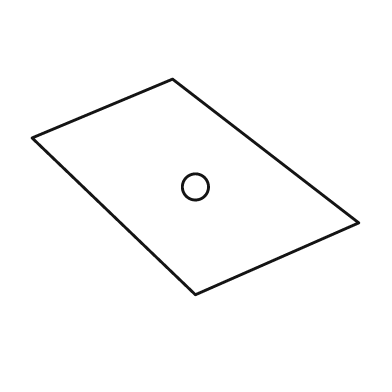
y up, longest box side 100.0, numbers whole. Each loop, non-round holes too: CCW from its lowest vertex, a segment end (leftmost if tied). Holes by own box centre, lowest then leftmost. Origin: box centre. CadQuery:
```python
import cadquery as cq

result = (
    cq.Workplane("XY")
    .moveTo(0.0, -33.0)
    .lineTo(50.0, -11.0)
    .lineTo(-7.0, 33.0)
    .lineTo(-50.0, 15.0)
    .close()
    .moveTo(0.0, 0.0)
    .circle(4.0)
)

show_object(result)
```